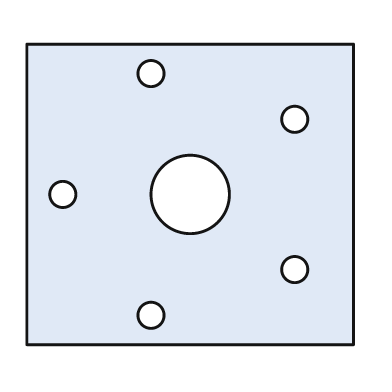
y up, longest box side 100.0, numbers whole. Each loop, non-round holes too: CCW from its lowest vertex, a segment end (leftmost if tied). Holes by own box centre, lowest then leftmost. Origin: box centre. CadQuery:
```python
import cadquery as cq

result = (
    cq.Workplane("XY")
    .moveTo(-50.0, -46.0)
    .lineTo(50.0, -46.0)
    .lineTo(50.0, 46.0)
    .lineTo(-50.0, 46.0)
    .close()
    .moveTo(-12.0, -37.0)
    .circle(4.0)
    .moveTo(32.0, -23.0)
    .circle(4.0)
    .moveTo(-39.0, 0.0)
    .circle(4.0)
    .moveTo(0.0, 0.0)
    .circle(12.0)
    .moveTo(32.0, 23.0)
    .circle(4.0)
    .moveTo(-12.0, 37.0)
    .circle(4.0)
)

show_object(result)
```